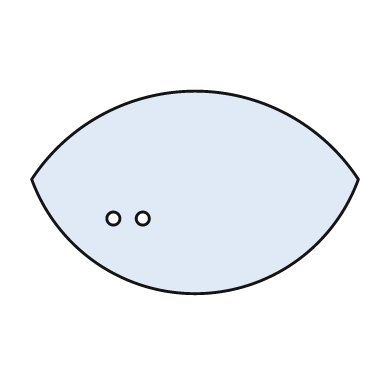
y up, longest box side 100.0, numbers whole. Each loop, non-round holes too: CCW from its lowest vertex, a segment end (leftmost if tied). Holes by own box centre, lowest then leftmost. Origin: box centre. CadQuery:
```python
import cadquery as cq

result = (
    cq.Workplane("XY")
    .moveTo(-50.0, 4.0)
    .threePointArc((0.0, -31.0), (50.0, 4.0))
    .threePointArc((0.0, 31.0), (-50.0, 4.0))
    .close()
    .moveTo(-25.0, -8.0)
    .circle(2.0)
    .moveTo(-16.0, -8.0)
    .circle(2.0)
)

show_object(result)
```